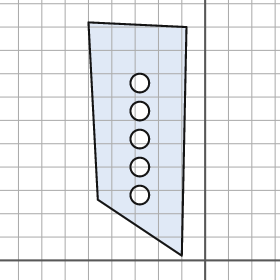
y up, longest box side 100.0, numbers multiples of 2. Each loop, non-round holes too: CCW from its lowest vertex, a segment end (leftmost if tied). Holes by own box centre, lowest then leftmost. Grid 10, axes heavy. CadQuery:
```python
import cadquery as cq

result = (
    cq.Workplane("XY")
    .moveTo(-10.0, 2.0)
    .lineTo(-8.0, 100.0)
    .lineTo(-50.0, 102.0)
    .lineTo(-46.0, 26.0)
    .close()
    .moveTo(-28.0, 28.0)
    .circle(4.0)
    .moveTo(-28.0, 40.0)
    .circle(4.0)
    .moveTo(-28.0, 52.0)
    .circle(4.0)
    .moveTo(-28.0, 64.0)
    .circle(4.0)
    .moveTo(-28.0, 76.0)
    .circle(4.0)
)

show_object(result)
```